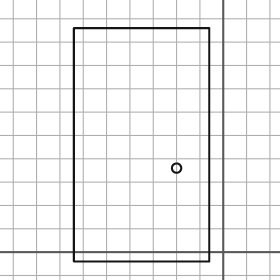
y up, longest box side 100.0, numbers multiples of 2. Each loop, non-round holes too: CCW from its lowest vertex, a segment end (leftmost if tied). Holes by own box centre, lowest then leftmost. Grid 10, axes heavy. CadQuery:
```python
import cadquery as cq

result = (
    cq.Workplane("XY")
    .moveTo(-64.0, -4.0)
    .lineTo(-6.0, -4.0)
    .lineTo(-6.0, 96.0)
    .lineTo(-64.0, 96.0)
    .close()
    .moveTo(-20.0, 36.0)
    .circle(2.0)
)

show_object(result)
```